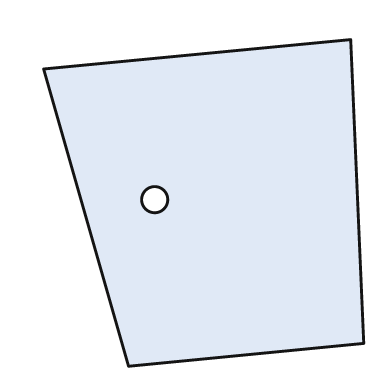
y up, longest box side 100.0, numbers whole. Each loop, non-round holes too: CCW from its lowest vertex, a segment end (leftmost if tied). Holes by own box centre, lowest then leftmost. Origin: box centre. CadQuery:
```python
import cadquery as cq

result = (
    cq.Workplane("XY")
    .moveTo(-23.0, -50.0)
    .lineTo(49.0, -43.0)
    .lineTo(45.0, 50.0)
    .lineTo(-49.0, 41.0)
    .close()
    .moveTo(-15.0, 1.0)
    .circle(4.0)
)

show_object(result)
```